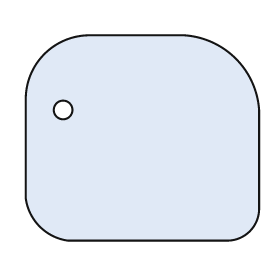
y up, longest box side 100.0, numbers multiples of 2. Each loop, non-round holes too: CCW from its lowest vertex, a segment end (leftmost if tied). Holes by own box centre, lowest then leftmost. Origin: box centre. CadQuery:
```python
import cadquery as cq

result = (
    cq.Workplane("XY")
    .moveTo(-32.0, -44.0)
    .lineTo(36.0, -44.0)
    .threePointArc((46.0, -40.0), (50.0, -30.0))
    .lineTo(50.0, 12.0)
    .threePointArc((40.0, 34.0), (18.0, 44.0))
    .lineTo(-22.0, 44.0)
    .threePointArc((-42.0, 36.0), (-50.0, 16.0))
    .lineTo(-50.0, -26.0)
    .threePointArc((-44.0, -38.0), (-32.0, -44.0))
    .close()
    .moveTo(-34.0, 12.0)
    .circle(4.0)
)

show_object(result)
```